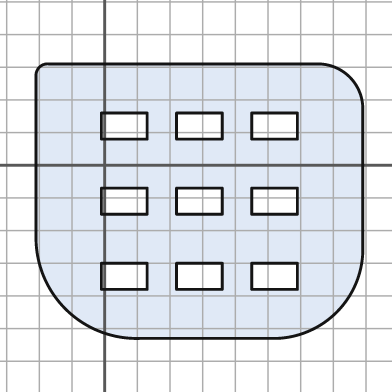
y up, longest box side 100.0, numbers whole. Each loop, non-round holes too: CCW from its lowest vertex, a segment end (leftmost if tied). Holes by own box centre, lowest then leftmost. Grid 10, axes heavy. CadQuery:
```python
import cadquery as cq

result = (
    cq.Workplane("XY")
    .moveTo(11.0, -53.0)
    .lineTo(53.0, -53.0)
    .threePointArc((71.0, -45.0), (79.0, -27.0))
    .lineTo(79.0, 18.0)
    .threePointArc((75.0, 27.0), (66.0, 31.0))
    .lineTo(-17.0, 31.0)
    .threePointArc((-20.0, 30.0), (-21.0, 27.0))
    .lineTo(-21.0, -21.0)
    .threePointArc((-12.0, -44.0), (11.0, -53.0))
    .close()
    .moveTo(-1.0, -38.0)
    .lineTo(13.0, -38.0)
    .lineTo(13.0, -30.0)
    .lineTo(-1.0, -30.0)
    .close()
    .moveTo(22.0, -38.0)
    .lineTo(36.0, -38.0)
    .lineTo(36.0, -30.0)
    .lineTo(22.0, -30.0)
    .close()
    .moveTo(45.0, -38.0)
    .lineTo(59.0, -38.0)
    .lineTo(59.0, -30.0)
    .lineTo(45.0, -30.0)
    .close()
    .moveTo(-1.0, -15.0)
    .lineTo(13.0, -15.0)
    .lineTo(13.0, -7.0)
    .lineTo(-1.0, -7.0)
    .close()
    .moveTo(22.0, -15.0)
    .lineTo(36.0, -15.0)
    .lineTo(36.0, -7.0)
    .lineTo(22.0, -7.0)
    .close()
    .moveTo(45.0, -15.0)
    .lineTo(59.0, -15.0)
    .lineTo(59.0, -7.0)
    .lineTo(45.0, -7.0)
    .close()
    .moveTo(-1.0, 8.0)
    .lineTo(13.0, 8.0)
    .lineTo(13.0, 16.0)
    .lineTo(-1.0, 16.0)
    .close()
    .moveTo(22.0, 8.0)
    .lineTo(36.0, 8.0)
    .lineTo(36.0, 16.0)
    .lineTo(22.0, 16.0)
    .close()
    .moveTo(45.0, 8.0)
    .lineTo(59.0, 8.0)
    .lineTo(59.0, 16.0)
    .lineTo(45.0, 16.0)
    .close()
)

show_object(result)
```